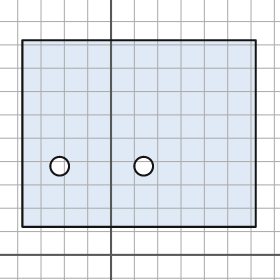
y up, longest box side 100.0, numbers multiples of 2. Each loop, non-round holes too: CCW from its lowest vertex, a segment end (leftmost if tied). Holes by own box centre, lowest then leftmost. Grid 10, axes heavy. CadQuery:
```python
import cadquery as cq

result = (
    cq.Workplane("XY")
    .moveTo(-38.0, 12.0)
    .lineTo(62.0, 12.0)
    .lineTo(62.0, 92.0)
    .lineTo(-38.0, 92.0)
    .close()
    .moveTo(-22.0, 38.0)
    .circle(4.0)
    .moveTo(14.0, 38.0)
    .circle(4.0)
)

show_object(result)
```